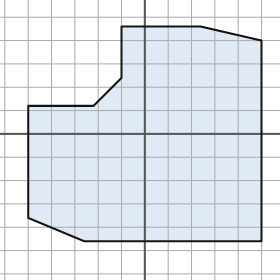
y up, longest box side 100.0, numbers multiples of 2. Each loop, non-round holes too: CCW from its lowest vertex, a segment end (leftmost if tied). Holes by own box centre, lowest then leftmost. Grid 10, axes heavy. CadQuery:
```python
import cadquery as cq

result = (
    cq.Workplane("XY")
    .moveTo(-26.0, -46.0)
    .lineTo(50.0, -46.0)
    .lineTo(50.0, 40.0)
    .lineTo(24.0, 46.0)
    .lineTo(-10.0, 46.0)
    .lineTo(-10.0, 24.0)
    .lineTo(-22.0, 12.0)
    .lineTo(-50.0, 12.0)
    .lineTo(-50.0, -36.0)
    .close()
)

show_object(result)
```